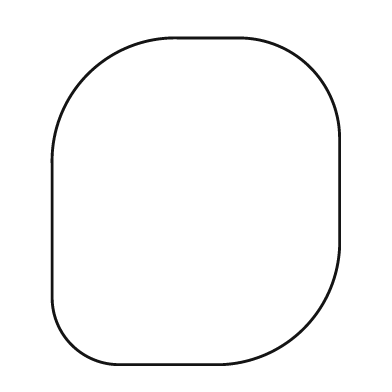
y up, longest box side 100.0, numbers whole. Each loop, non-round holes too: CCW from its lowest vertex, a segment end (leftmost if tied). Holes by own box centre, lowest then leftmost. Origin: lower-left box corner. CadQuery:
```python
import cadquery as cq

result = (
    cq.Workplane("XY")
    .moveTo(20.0, 0.0)
    .lineTo(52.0, 0.0)
    .threePointArc((77.0, 11.0), (88.0, 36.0))
    .lineTo(88.0, 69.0)
    .threePointArc((79.0, 91.0), (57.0, 100.0))
    .lineTo(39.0, 100.0)
    .threePointArc((11.0, 89.0), (0.0, 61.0))
    .lineTo(0.0, 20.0)
    .threePointArc((6.0, 6.0), (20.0, 0.0))
    .close()
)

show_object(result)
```